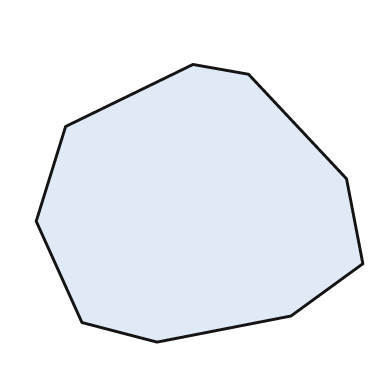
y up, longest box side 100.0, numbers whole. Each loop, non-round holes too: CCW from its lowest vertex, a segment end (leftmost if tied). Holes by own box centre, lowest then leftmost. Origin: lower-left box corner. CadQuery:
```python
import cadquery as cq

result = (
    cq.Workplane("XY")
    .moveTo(37.0, 0.0)
    .lineTo(78.0, 8.0)
    .lineTo(100.0, 24.0)
    .lineTo(95.0, 50.0)
    .lineTo(65.0, 82.0)
    .lineTo(48.0, 85.0)
    .lineTo(9.0, 66.0)
    .lineTo(0.0, 37.0)
    .lineTo(14.0, 6.0)
    .close()
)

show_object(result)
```